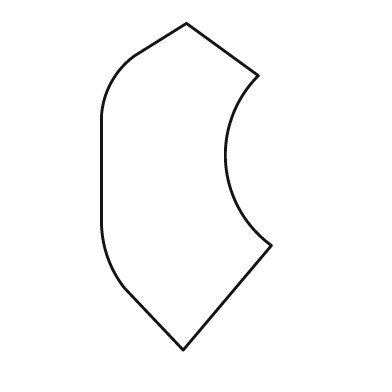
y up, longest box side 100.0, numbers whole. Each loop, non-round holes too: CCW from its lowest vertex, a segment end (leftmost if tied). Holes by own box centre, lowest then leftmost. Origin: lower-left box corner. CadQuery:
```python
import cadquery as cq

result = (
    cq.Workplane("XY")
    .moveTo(25.0, 0.0)
    .lineTo(52.0, 32.0)
    .threePointArc((38.0, 57.0), (48.0, 84.0))
    .lineTo(26.0, 100.0)
    .lineTo(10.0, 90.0)
    .threePointArc((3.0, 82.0), (0.0, 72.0))
    .lineTo(0.0, 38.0)
    .threePointArc((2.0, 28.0), (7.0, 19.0))
    .close()
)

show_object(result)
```